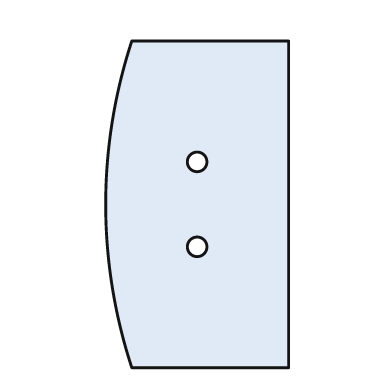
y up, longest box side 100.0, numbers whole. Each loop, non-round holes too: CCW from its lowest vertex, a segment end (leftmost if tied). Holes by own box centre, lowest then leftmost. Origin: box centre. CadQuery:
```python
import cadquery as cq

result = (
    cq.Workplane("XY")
    .moveTo(-20.0, -50.0)
    .lineTo(28.0, -50.0)
    .lineTo(28.0, 50.0)
    .lineTo(-20.0, 50.0)
    .threePointArc((-28.0, 0.0), (-20.0, -50.0))
    .close()
    .moveTo(0.0, -13.0)
    .circle(3.0)
    .moveTo(0.0, 13.0)
    .circle(3.0)
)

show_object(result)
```